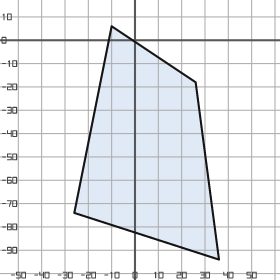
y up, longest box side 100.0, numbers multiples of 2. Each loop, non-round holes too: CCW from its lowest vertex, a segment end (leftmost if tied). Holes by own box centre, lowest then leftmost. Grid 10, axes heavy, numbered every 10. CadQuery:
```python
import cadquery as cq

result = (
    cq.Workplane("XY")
    .moveTo(36.0, -94.0)
    .lineTo(26.0, -18.0)
    .lineTo(-10.0, 6.0)
    .lineTo(-26.0, -74.0)
    .close()
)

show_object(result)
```